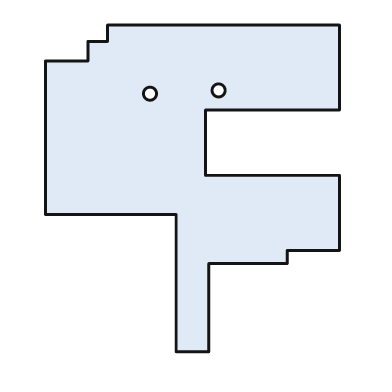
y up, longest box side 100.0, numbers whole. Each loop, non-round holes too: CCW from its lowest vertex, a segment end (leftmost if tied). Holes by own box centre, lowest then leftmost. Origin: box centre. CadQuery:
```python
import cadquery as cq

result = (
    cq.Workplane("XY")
    .moveTo(-5.0, -50.0)
    .lineTo(5.0, -50.0)
    .lineTo(5.0, -23.0)
    .lineTo(29.0, -23.0)
    .lineTo(29.0, -19.0)
    .lineTo(45.0, -19.0)
    .lineTo(45.0, 4.0)
    .lineTo(4.0, 4.0)
    .lineTo(4.0, 24.0)
    .lineTo(45.0, 24.0)
    .lineTo(45.0, 50.0)
    .lineTo(-26.0, 50.0)
    .lineTo(-26.0, 45.0)
    .lineTo(-32.0, 45.0)
    .lineTo(-32.0, 39.0)
    .lineTo(-45.0, 39.0)
    .lineTo(-45.0, -8.0)
    .lineTo(-5.0, -8.0)
    .close()
    .moveTo(-13.0, 29.0)
    .circle(2.0)
    .moveTo(8.0, 30.0)
    .circle(2.0)
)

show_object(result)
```